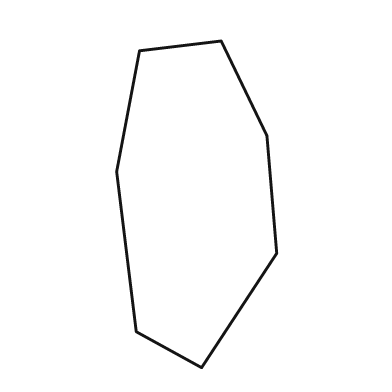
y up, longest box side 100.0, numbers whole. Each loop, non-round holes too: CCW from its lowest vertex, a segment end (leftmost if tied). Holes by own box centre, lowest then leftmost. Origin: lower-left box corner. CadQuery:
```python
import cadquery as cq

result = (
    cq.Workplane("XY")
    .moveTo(26.0, 0.0)
    .lineTo(49.0, 35.0)
    .lineTo(46.0, 71.0)
    .lineTo(32.0, 100.0)
    .lineTo(7.0, 97.0)
    .lineTo(0.0, 60.0)
    .lineTo(6.0, 11.0)
    .close()
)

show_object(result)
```